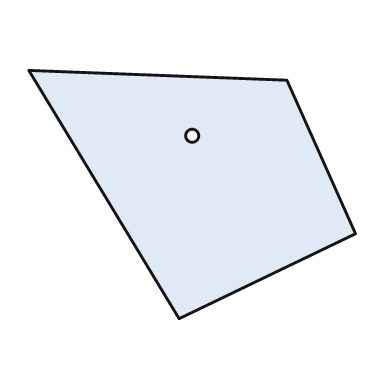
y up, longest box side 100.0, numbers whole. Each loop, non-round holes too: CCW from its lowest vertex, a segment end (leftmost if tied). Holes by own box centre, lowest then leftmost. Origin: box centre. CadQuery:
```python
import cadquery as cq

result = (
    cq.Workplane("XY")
    .moveTo(-4.0, -38.0)
    .lineTo(50.0, -12.0)
    .lineTo(29.0, 35.0)
    .lineTo(-50.0, 38.0)
    .close()
    .moveTo(0.0, 18.0)
    .circle(2.0)
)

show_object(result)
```